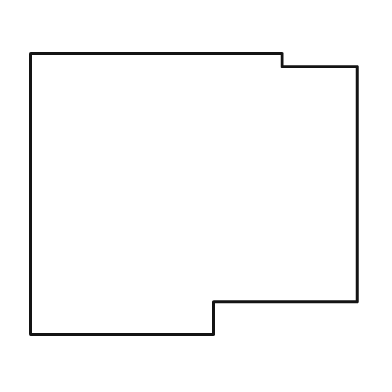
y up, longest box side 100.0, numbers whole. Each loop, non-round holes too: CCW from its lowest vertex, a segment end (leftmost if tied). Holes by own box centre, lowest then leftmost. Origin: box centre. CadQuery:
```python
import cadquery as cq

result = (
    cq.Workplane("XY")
    .moveTo(-50.0, -43.0)
    .lineTo(6.0, -43.0)
    .lineTo(6.0, -33.0)
    .lineTo(50.0, -33.0)
    .lineTo(50.0, 39.0)
    .lineTo(27.0, 39.0)
    .lineTo(27.0, 43.0)
    .lineTo(-50.0, 43.0)
    .close()
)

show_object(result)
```